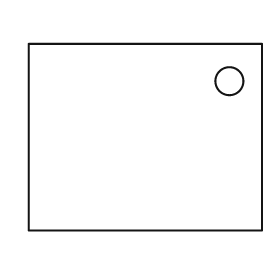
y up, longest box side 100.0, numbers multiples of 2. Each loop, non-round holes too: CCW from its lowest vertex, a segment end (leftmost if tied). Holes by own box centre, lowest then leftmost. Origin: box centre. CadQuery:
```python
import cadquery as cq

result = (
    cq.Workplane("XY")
    .moveTo(-50.0, -40.0)
    .lineTo(50.0, -40.0)
    .lineTo(50.0, 40.0)
    .lineTo(-50.0, 40.0)
    .close()
    .moveTo(36.0, 24.0)
    .circle(6.0)
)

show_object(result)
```